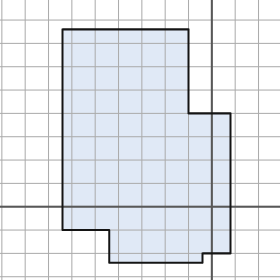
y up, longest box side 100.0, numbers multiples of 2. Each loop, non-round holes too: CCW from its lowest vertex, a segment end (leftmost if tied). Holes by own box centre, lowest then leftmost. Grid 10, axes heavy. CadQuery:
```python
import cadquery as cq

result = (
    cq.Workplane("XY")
    .moveTo(-44.0, -24.0)
    .lineTo(-4.0, -24.0)
    .lineTo(-4.0, -20.0)
    .lineTo(8.0, -20.0)
    .lineTo(8.0, 40.0)
    .lineTo(-10.0, 40.0)
    .lineTo(-10.0, 76.0)
    .lineTo(-64.0, 76.0)
    .lineTo(-64.0, -10.0)
    .lineTo(-44.0, -10.0)
    .close()
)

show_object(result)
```